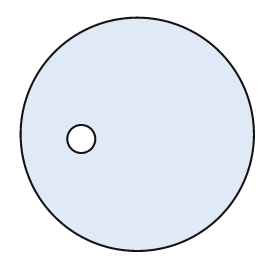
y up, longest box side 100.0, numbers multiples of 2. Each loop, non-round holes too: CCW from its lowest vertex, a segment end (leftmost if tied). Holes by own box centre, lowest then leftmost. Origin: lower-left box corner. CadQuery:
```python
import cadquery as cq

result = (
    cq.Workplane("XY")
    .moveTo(50.0, 50.0)
    .circle(50.0)
    .moveTo(26.0, 48.0)
    .circle(6.0)
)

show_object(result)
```